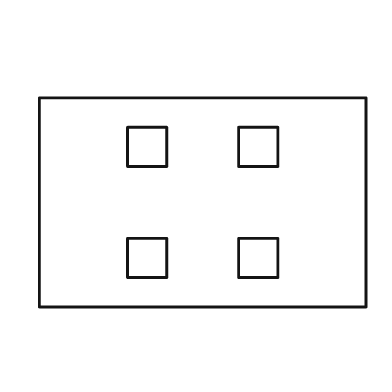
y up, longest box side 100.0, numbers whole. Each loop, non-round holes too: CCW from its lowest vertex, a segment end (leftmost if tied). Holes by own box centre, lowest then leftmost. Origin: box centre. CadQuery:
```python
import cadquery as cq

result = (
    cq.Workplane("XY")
    .moveTo(-50.0, -32.0)
    .lineTo(50.0, -32.0)
    .lineTo(50.0, 32.0)
    .lineTo(-50.0, 32.0)
    .close()
    .moveTo(-23.0, -23.0)
    .lineTo(-11.0, -23.0)
    .lineTo(-11.0, -11.0)
    .lineTo(-23.0, -11.0)
    .close()
    .moveTo(11.0, -23.0)
    .lineTo(23.0, -23.0)
    .lineTo(23.0, -11.0)
    .lineTo(11.0, -11.0)
    .close()
    .moveTo(-23.0, 11.0)
    .lineTo(-11.0, 11.0)
    .lineTo(-11.0, 23.0)
    .lineTo(-23.0, 23.0)
    .close()
    .moveTo(11.0, 11.0)
    .lineTo(23.0, 11.0)
    .lineTo(23.0, 23.0)
    .lineTo(11.0, 23.0)
    .close()
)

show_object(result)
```